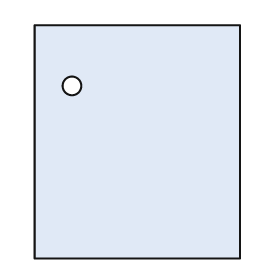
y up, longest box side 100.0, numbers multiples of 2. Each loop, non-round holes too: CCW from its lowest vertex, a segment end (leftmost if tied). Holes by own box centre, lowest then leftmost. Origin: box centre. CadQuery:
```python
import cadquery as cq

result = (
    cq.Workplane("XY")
    .moveTo(-44.0, -50.0)
    .lineTo(44.0, -50.0)
    .lineTo(44.0, 50.0)
    .lineTo(-44.0, 50.0)
    .close()
    .moveTo(-28.0, 24.0)
    .circle(4.0)
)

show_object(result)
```